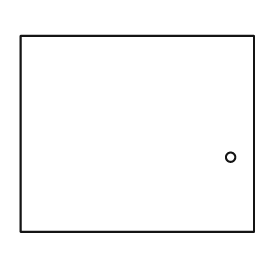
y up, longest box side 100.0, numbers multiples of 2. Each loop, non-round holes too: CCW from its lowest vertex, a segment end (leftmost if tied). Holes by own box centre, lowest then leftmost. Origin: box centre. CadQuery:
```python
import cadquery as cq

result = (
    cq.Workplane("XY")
    .moveTo(-50.0, -42.0)
    .lineTo(50.0, -42.0)
    .lineTo(50.0, 42.0)
    .lineTo(-50.0, 42.0)
    .close()
    .moveTo(40.0, -10.0)
    .circle(2.0)
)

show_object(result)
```